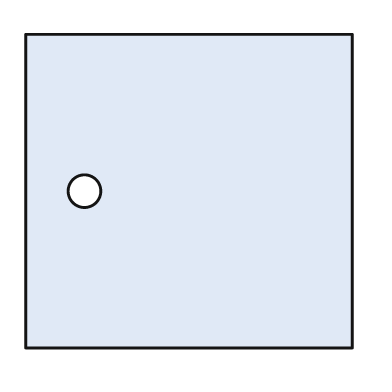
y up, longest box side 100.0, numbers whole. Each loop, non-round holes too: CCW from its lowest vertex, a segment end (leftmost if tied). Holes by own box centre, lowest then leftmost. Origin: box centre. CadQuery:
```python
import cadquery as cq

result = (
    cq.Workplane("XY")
    .moveTo(-50.0, -48.0)
    .lineTo(50.0, -48.0)
    .lineTo(50.0, 48.0)
    .lineTo(-50.0, 48.0)
    .close()
    .moveTo(-32.0, 0.0)
    .circle(5.0)
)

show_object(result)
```